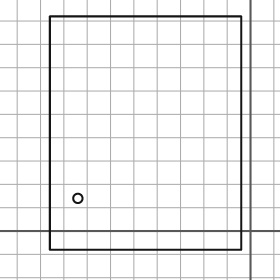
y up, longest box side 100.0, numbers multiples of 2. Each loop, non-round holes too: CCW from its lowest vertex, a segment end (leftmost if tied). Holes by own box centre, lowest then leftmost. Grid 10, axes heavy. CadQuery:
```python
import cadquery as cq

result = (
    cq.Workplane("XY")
    .moveTo(-86.0, -8.0)
    .lineTo(-4.0, -8.0)
    .lineTo(-4.0, 92.0)
    .lineTo(-86.0, 92.0)
    .close()
    .moveTo(-74.0, 14.0)
    .circle(2.0)
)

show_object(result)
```